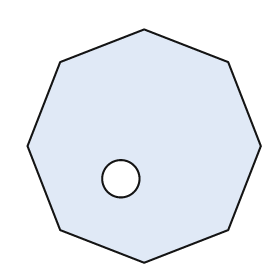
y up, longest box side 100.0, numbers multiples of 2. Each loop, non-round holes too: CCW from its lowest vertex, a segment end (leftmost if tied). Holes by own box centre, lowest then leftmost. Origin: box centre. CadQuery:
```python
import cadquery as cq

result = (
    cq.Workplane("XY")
    .moveTo(0.0, -50.0)
    .lineTo(36.0, -36.0)
    .lineTo(50.0, 0.0)
    .lineTo(36.0, 36.0)
    .lineTo(0.0, 50.0)
    .lineTo(-36.0, 36.0)
    .lineTo(-50.0, 0.0)
    .lineTo(-36.0, -36.0)
    .close()
    .moveTo(-10.0, -14.0)
    .circle(8.0)
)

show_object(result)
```